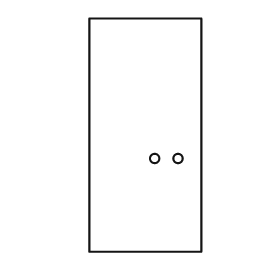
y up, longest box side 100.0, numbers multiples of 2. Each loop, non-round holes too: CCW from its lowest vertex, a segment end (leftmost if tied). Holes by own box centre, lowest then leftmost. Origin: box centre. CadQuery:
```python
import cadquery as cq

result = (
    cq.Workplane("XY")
    .moveTo(-24.0, -50.0)
    .lineTo(24.0, -50.0)
    .lineTo(24.0, 50.0)
    .lineTo(-24.0, 50.0)
    .close()
    .moveTo(4.0, -10.0)
    .circle(2.0)
    .moveTo(14.0, -10.0)
    .circle(2.0)
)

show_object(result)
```